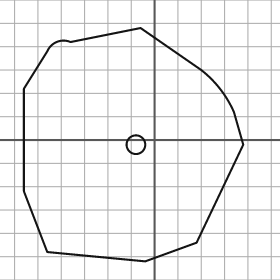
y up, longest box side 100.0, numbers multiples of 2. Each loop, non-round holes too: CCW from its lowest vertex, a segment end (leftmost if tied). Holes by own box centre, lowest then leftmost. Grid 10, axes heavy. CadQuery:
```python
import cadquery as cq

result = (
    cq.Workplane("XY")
    .moveTo(-4.0, -52.0)
    .lineTo(18.0, -44.0)
    .lineTo(38.0, -2.0)
    .lineTo(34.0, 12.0)
    .threePointArc((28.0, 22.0), (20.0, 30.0))
    .lineTo(-6.0, 48.0)
    .lineTo(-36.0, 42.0)
    .threePointArc((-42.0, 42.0), (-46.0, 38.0))
    .lineTo(-56.0, 22.0)
    .lineTo(-56.0, -22.0)
    .lineTo(-46.0, -48.0)
    .close()
    .moveTo(-8.0, -2.0)
    .circle(4.0)
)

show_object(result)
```